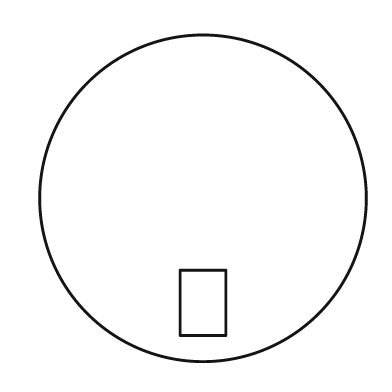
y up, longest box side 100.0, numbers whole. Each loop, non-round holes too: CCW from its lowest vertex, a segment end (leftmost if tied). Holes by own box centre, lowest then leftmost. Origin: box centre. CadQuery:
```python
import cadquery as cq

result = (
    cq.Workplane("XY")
    .moveTo(0.0, 0.0)
    .circle(50.0)
    .moveTo(-7.0, -42.0)
    .lineTo(7.0, -42.0)
    .lineTo(7.0, -22.0)
    .lineTo(-7.0, -22.0)
    .close()
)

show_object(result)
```